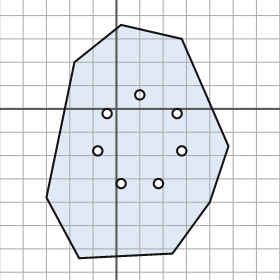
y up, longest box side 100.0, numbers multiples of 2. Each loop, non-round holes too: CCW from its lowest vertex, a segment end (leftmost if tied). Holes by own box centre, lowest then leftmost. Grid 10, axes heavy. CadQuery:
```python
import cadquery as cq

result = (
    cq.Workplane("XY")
    .moveTo(-16.0, -64.0)
    .lineTo(24.0, -62.0)
    .lineTo(40.0, -40.0)
    .lineTo(48.0, -16.0)
    .lineTo(28.0, 30.0)
    .lineTo(2.0, 36.0)
    .lineTo(-18.0, 20.0)
    .lineTo(-30.0, -38.0)
    .close()
    .moveTo(2.0, -32.0)
    .circle(2.0)
    .moveTo(18.0, -32.0)
    .circle(2.0)
    .moveTo(-8.0, -18.0)
    .circle(2.0)
    .moveTo(28.0, -18.0)
    .circle(2.0)
    .moveTo(-4.0, -2.0)
    .circle(2.0)
    .moveTo(26.0, -2.0)
    .circle(2.0)
    .moveTo(10.0, 6.0)
    .circle(2.0)
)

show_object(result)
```